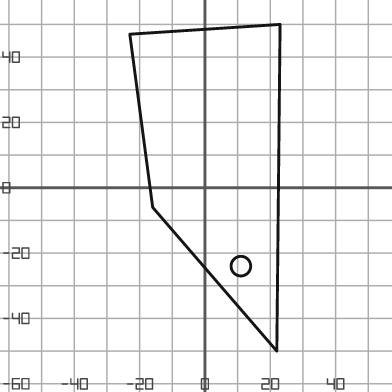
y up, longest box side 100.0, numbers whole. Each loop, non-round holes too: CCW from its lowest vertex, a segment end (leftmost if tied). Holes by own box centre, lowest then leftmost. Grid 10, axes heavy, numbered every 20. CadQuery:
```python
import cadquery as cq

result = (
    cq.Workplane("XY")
    .moveTo(22.0, -50.0)
    .lineTo(23.0, 50.0)
    .lineTo(-23.0, 47.0)
    .lineTo(-16.0, -6.0)
    .close()
    .moveTo(11.0, -24.0)
    .circle(3.0)
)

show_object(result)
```